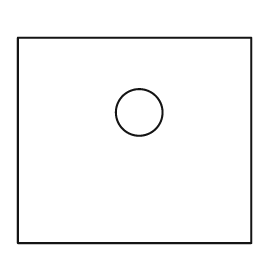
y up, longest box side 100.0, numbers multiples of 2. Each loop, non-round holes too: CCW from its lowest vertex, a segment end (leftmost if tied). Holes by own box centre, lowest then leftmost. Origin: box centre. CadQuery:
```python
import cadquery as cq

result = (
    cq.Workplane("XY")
    .moveTo(-50.0, -44.0)
    .lineTo(50.0, -44.0)
    .lineTo(50.0, 44.0)
    .lineTo(-50.0, 44.0)
    .close()
    .moveTo(2.0, 12.0)
    .circle(10.0)
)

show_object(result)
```